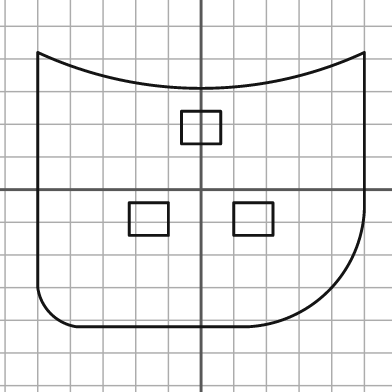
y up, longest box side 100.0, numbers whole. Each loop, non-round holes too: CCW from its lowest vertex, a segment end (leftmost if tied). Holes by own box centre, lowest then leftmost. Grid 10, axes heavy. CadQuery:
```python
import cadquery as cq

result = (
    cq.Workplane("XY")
    .moveTo(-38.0, -42.0)
    .lineTo(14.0, -42.0)
    .threePointArc((39.0, -31.0), (50.0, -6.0))
    .lineTo(50.0, 42.0)
    .threePointArc((0.0, 31.0), (-50.0, 42.0))
    .lineTo(-50.0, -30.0)
    .threePointArc((-46.0, -38.0), (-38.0, -42.0))
    .close()
    .moveTo(-22.0, -14.0)
    .lineTo(-10.0, -14.0)
    .lineTo(-10.0, -4.0)
    .lineTo(-22.0, -4.0)
    .close()
    .moveTo(10.0, -14.0)
    .lineTo(22.0, -14.0)
    .lineTo(22.0, -4.0)
    .lineTo(10.0, -4.0)
    .close()
    .moveTo(-6.0, 14.0)
    .lineTo(6.0, 14.0)
    .lineTo(6.0, 24.0)
    .lineTo(-6.0, 24.0)
    .close()
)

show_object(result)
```